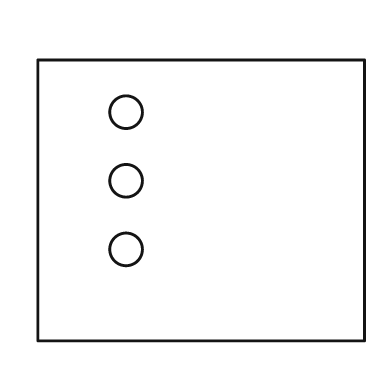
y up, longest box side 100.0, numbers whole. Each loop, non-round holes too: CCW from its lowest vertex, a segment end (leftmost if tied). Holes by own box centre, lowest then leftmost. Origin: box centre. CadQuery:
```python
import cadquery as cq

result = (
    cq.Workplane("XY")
    .moveTo(-50.0, -43.0)
    .lineTo(50.0, -43.0)
    .lineTo(50.0, 43.0)
    .lineTo(-50.0, 43.0)
    .close()
    .moveTo(-23.0, -15.0)
    .circle(5.0)
    .moveTo(-23.0, 6.0)
    .circle(5.0)
    .moveTo(-23.0, 27.0)
    .circle(5.0)
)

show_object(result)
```